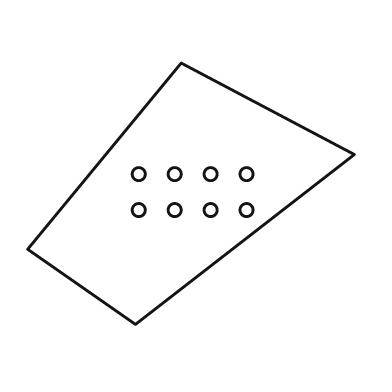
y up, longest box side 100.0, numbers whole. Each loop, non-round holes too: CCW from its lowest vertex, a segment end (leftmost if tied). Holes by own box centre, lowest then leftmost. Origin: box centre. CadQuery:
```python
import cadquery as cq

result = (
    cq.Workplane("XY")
    .moveTo(-17.0, -40.0)
    .lineTo(50.0, 12.0)
    .lineTo(-3.0, 40.0)
    .lineTo(-50.0, -17.0)
    .close()
    .moveTo(-16.0, -5.0)
    .circle(2.0)
    .moveTo(-5.0, -5.0)
    .circle(2.0)
    .moveTo(6.0, -5.0)
    .circle(2.0)
    .moveTo(17.0, -5.0)
    .circle(2.0)
    .moveTo(-16.0, 6.0)
    .circle(2.0)
    .moveTo(-5.0, 6.0)
    .circle(2.0)
    .moveTo(6.0, 6.0)
    .circle(2.0)
    .moveTo(17.0, 6.0)
    .circle(2.0)
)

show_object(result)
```